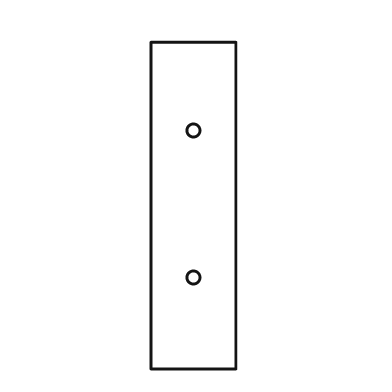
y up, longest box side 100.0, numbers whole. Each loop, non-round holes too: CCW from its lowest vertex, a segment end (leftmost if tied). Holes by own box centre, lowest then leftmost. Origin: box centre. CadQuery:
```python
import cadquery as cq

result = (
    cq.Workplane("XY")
    .moveTo(-13.0, -50.0)
    .lineTo(13.0, -50.0)
    .lineTo(13.0, 50.0)
    .lineTo(-13.0, 50.0)
    .close()
    .moveTo(0.0, -22.0)
    .circle(2.0)
    .moveTo(0.0, 23.0)
    .circle(2.0)
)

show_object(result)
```